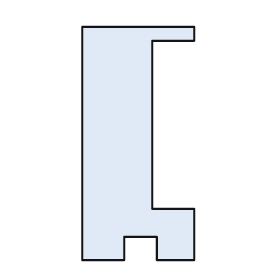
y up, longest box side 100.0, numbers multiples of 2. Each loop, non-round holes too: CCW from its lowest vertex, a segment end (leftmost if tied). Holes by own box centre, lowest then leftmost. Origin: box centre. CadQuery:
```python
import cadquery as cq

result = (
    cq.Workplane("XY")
    .moveTo(-24.0, -50.0)
    .lineTo(-6.0, -50.0)
    .lineTo(-6.0, -40.0)
    .lineTo(8.0, -40.0)
    .lineTo(8.0, -50.0)
    .lineTo(24.0, -50.0)
    .lineTo(24.0, -28.0)
    .lineTo(6.0, -28.0)
    .lineTo(6.0, 44.0)
    .lineTo(24.0, 44.0)
    .lineTo(24.0, 50.0)
    .lineTo(-24.0, 50.0)
    .close()
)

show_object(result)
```